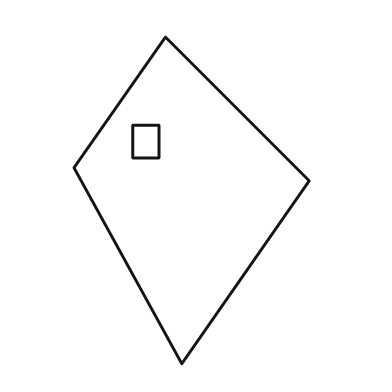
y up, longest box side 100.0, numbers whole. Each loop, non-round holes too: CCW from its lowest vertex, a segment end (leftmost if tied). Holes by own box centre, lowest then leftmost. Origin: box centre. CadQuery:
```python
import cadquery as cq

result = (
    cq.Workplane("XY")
    .moveTo(-3.0, -50.0)
    .lineTo(36.0, 6.0)
    .lineTo(-8.0, 50.0)
    .lineTo(-36.0, 10.0)
    .close()
    .moveTo(-18.0, 13.0)
    .lineTo(-10.0, 13.0)
    .lineTo(-10.0, 23.0)
    .lineTo(-18.0, 23.0)
    .close()
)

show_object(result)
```